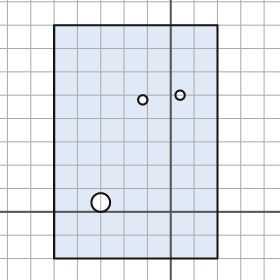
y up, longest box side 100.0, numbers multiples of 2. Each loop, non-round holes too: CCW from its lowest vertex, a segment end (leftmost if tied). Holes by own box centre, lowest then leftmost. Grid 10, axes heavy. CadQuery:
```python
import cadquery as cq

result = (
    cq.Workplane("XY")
    .moveTo(-50.0, -20.0)
    .lineTo(20.0, -20.0)
    .lineTo(20.0, 80.0)
    .lineTo(-50.0, 80.0)
    .close()
    .moveTo(-30.0, 4.0)
    .circle(4.0)
    .moveTo(-12.0, 48.0)
    .circle(2.0)
    .moveTo(4.0, 50.0)
    .circle(2.0)
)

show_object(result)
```